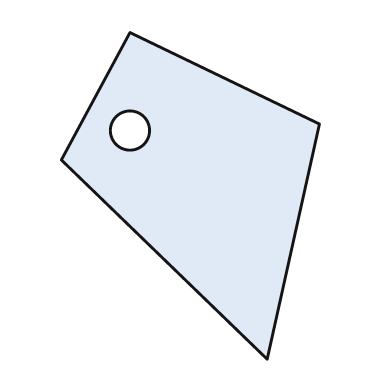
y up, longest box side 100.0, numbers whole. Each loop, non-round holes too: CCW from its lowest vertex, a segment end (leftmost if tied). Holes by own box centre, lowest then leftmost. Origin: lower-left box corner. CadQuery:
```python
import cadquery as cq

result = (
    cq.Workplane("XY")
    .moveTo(63.0, 0.0)
    .lineTo(79.0, 72.0)
    .lineTo(21.0, 100.0)
    .lineTo(0.0, 61.0)
    .close()
    .moveTo(21.0, 70.0)
    .circle(6.0)
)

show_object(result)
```